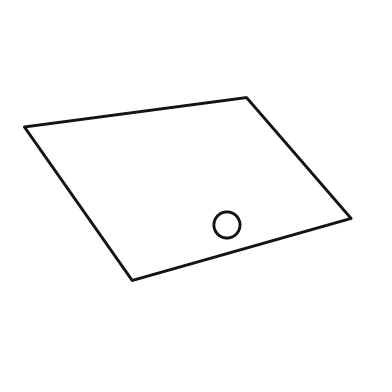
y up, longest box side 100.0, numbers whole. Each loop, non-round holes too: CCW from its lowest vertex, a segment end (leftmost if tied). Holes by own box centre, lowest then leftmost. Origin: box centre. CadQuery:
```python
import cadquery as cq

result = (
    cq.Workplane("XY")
    .moveTo(-17.0, -28.0)
    .lineTo(50.0, -9.0)
    .lineTo(18.0, 28.0)
    .lineTo(-50.0, 19.0)
    .close()
    .moveTo(12.0, -11.0)
    .circle(4.0)
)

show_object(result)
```